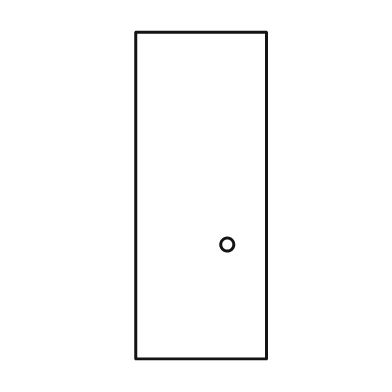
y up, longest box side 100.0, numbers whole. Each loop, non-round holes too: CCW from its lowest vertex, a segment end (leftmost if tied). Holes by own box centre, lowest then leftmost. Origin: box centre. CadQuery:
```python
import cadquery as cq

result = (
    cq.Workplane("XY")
    .moveTo(-20.0, -50.0)
    .lineTo(20.0, -50.0)
    .lineTo(20.0, 50.0)
    .lineTo(-20.0, 50.0)
    .close()
    .moveTo(8.0, -15.0)
    .circle(2.0)
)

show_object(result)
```